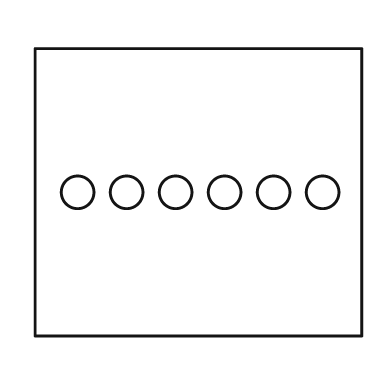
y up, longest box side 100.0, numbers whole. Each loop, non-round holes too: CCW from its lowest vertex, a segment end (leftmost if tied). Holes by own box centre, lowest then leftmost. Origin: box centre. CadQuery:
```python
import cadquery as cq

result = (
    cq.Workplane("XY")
    .moveTo(-50.0, -44.0)
    .lineTo(50.0, -44.0)
    .lineTo(50.0, 44.0)
    .lineTo(-50.0, 44.0)
    .close()
    .moveTo(-37.0, 0.0)
    .circle(5.0)
    .moveTo(-22.0, 0.0)
    .circle(5.0)
    .moveTo(-7.0, 0.0)
    .circle(5.0)
    .moveTo(8.0, 0.0)
    .circle(5.0)
    .moveTo(23.0, 0.0)
    .circle(5.0)
    .moveTo(38.0, 0.0)
    .circle(5.0)
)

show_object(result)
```